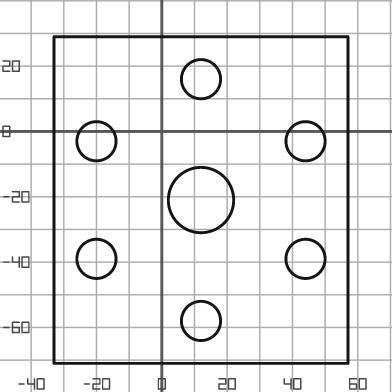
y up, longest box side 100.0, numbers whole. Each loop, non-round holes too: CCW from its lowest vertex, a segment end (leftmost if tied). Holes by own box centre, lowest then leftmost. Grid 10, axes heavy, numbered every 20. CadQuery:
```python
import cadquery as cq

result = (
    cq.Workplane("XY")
    .moveTo(-33.0, -71.0)
    .lineTo(57.0, -71.0)
    .lineTo(57.0, 29.0)
    .lineTo(-33.0, 29.0)
    .close()
    .moveTo(12.0, -58.0)
    .circle(6.0)
    .moveTo(-20.0, -39.0)
    .circle(6.0)
    .moveTo(44.0, -39.0)
    .circle(6.0)
    .moveTo(12.0, -21.0)
    .circle(10.0)
    .moveTo(-20.0, -3.0)
    .circle(6.0)
    .moveTo(44.0, -3.0)
    .circle(6.0)
    .moveTo(12.0, 16.0)
    .circle(6.0)
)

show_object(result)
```